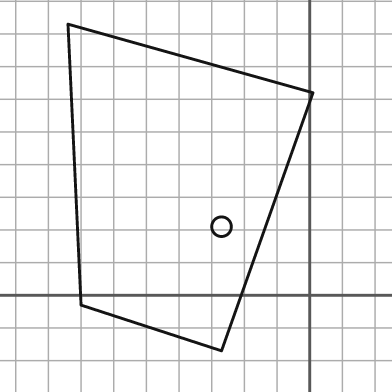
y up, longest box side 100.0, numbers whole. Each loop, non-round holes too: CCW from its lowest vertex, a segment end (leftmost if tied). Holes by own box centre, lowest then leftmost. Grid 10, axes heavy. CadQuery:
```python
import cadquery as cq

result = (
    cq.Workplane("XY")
    .moveTo(-27.0, -17.0)
    .lineTo(1.0, 62.0)
    .lineTo(-74.0, 83.0)
    .lineTo(-70.0, -3.0)
    .close()
    .moveTo(-27.0, 21.0)
    .circle(3.0)
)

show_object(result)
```